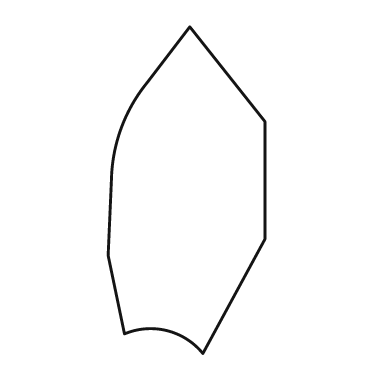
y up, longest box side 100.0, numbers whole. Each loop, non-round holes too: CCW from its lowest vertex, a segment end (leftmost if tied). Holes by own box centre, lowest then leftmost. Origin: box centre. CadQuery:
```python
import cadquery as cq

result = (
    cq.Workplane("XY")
    .moveTo(5.0, -50.0)
    .lineTo(24.0, -15.0)
    .lineTo(24.0, 21.0)
    .lineTo(1.0, 50.0)
    .lineTo(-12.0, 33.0)
    .threePointArc((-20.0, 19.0), (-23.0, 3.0))
    .lineTo(-24.0, -20.0)
    .lineTo(-19.0, -44.0)
    .threePointArc((-6.0, -43.0), (5.0, -50.0))
    .close()
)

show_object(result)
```